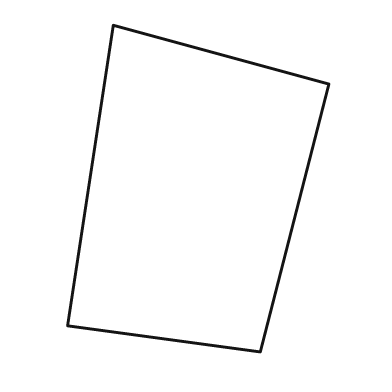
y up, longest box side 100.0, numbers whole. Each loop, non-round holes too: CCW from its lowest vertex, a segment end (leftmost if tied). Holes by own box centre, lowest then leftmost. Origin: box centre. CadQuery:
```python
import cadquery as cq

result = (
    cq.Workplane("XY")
    .moveTo(19.0, -50.0)
    .lineTo(40.0, 32.0)
    .lineTo(-26.0, 50.0)
    .lineTo(-40.0, -42.0)
    .close()
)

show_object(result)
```